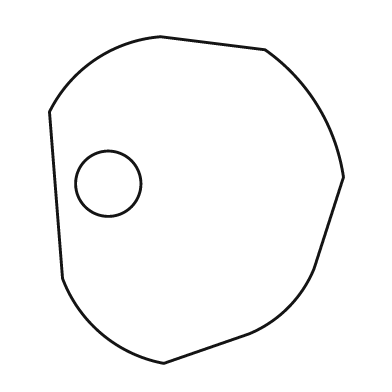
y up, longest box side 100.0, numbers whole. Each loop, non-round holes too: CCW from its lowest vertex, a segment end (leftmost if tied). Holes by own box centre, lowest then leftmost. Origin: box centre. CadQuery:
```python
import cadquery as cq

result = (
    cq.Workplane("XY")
    .moveTo(-10.0, -50.0)
    .lineTo(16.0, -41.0)
    .threePointArc((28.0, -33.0), (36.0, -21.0))
    .lineTo(45.0, 7.0)
    .threePointArc((37.0, 29.0), (21.0, 46.0))
    .lineTo(-11.0, 50.0)
    .threePointArc((-31.0, 43.0), (-45.0, 27.0))
    .lineTo(-41.0, -24.0)
    .threePointArc((-29.0, -41.0), (-10.0, -50.0))
    .close()
    .moveTo(-27.0, 5.0)
    .circle(10.0)
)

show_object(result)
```